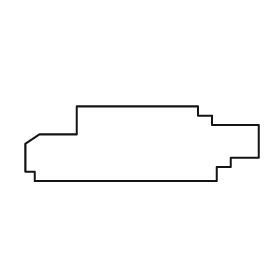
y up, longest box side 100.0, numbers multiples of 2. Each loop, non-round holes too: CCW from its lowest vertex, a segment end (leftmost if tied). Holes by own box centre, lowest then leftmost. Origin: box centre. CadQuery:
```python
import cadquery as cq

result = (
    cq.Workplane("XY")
    .moveTo(-46.0, -16.0)
    .lineTo(32.0, -16.0)
    .lineTo(32.0, -10.0)
    .lineTo(38.0, -10.0)
    .lineTo(38.0, -6.0)
    .lineTo(50.0, -6.0)
    .lineTo(50.0, 8.0)
    .lineTo(30.0, 8.0)
    .lineTo(30.0, 12.0)
    .lineTo(24.0, 12.0)
    .lineTo(24.0, 16.0)
    .lineTo(-28.0, 16.0)
    .lineTo(-28.0, 4.0)
    .lineTo(-44.0, 4.0)
    .lineTo(-50.0, 0.0)
    .lineTo(-50.0, -12.0)
    .lineTo(-46.0, -12.0)
    .close()
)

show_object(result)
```